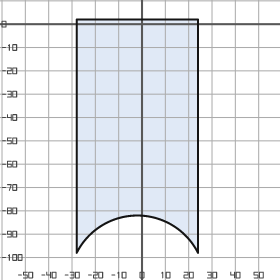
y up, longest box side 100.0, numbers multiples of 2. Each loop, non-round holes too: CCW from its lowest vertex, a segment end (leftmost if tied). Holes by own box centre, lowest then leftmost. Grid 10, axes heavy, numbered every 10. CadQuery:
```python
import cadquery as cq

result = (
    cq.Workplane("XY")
    .moveTo(-28.0, -98.0)
    .threePointArc((-2.0, -82.0), (24.0, -98.0))
    .lineTo(24.0, 2.0)
    .lineTo(-28.0, 2.0)
    .close()
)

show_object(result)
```